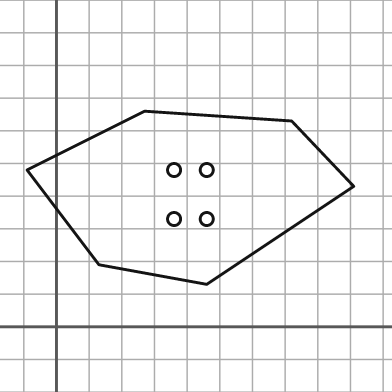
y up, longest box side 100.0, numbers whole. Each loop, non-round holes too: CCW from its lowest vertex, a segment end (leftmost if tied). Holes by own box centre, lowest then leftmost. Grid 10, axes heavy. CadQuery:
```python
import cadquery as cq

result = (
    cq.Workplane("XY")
    .moveTo(46.0, 13.0)
    .lineTo(91.0, 43.0)
    .lineTo(72.0, 63.0)
    .lineTo(27.0, 66.0)
    .lineTo(-9.0, 48.0)
    .lineTo(13.0, 19.0)
    .close()
    .moveTo(36.0, 33.0)
    .circle(2.0)
    .moveTo(46.0, 33.0)
    .circle(2.0)
    .moveTo(36.0, 48.0)
    .circle(2.0)
    .moveTo(46.0, 48.0)
    .circle(2.0)
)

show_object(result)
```